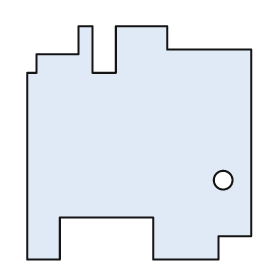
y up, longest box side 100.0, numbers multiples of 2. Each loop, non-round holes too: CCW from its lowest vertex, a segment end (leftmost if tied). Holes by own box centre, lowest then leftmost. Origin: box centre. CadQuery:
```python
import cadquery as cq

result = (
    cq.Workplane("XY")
    .moveTo(-48.0, -50.0)
    .lineTo(-34.0, -50.0)
    .lineTo(-34.0, -32.0)
    .lineTo(6.0, -32.0)
    .lineTo(6.0, -50.0)
    .lineTo(34.0, -50.0)
    .lineTo(34.0, -40.0)
    .lineTo(48.0, -40.0)
    .lineTo(48.0, 40.0)
    .lineTo(12.0, 40.0)
    .lineTo(12.0, 50.0)
    .lineTo(-10.0, 50.0)
    .lineTo(-10.0, 30.0)
    .lineTo(-20.0, 30.0)
    .lineTo(-20.0, 50.0)
    .lineTo(-26.0, 50.0)
    .lineTo(-26.0, 38.0)
    .lineTo(-44.0, 38.0)
    .lineTo(-44.0, 30.0)
    .lineTo(-48.0, 30.0)
    .close()
    .moveTo(36.0, -16.0)
    .circle(4.0)
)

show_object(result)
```